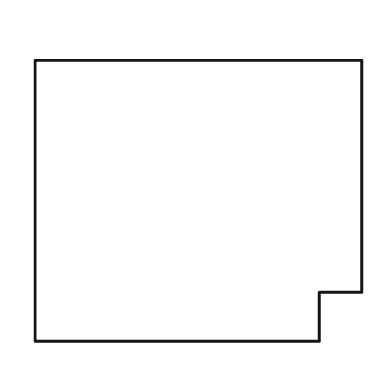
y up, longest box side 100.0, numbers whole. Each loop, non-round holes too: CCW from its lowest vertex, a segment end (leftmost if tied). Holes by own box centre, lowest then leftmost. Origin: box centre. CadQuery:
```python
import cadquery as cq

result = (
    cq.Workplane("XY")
    .moveTo(-50.0, -43.0)
    .lineTo(37.0, -43.0)
    .lineTo(37.0, -28.0)
    .lineTo(50.0, -28.0)
    .lineTo(50.0, 43.0)
    .lineTo(-50.0, 43.0)
    .close()
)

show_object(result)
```